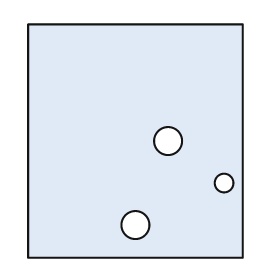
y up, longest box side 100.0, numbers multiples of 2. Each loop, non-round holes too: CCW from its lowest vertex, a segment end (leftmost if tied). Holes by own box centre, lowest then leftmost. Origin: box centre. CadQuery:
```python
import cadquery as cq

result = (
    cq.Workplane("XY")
    .moveTo(-46.0, -50.0)
    .lineTo(46.0, -50.0)
    .lineTo(46.0, 50.0)
    .lineTo(-46.0, 50.0)
    .close()
    .moveTo(0.0, -36.0)
    .circle(6.0)
    .moveTo(38.0, -18.0)
    .circle(4.0)
    .moveTo(14.0, 0.0)
    .circle(6.0)
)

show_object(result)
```